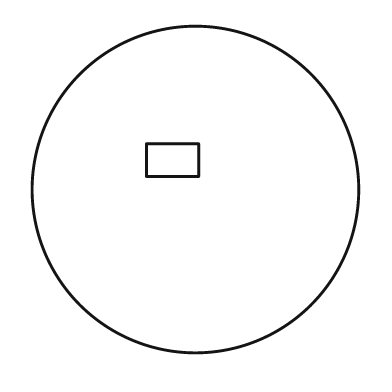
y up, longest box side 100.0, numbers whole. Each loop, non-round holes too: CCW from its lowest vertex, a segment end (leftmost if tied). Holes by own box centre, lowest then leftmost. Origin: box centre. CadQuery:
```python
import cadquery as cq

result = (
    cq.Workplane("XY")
    .moveTo(0.0, 0.0)
    .circle(50.0)
    .moveTo(-15.0, 4.0)
    .lineTo(1.0, 4.0)
    .lineTo(1.0, 14.0)
    .lineTo(-15.0, 14.0)
    .close()
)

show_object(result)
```